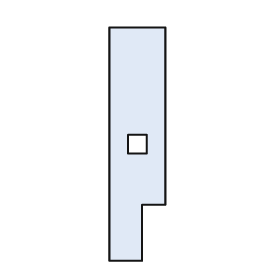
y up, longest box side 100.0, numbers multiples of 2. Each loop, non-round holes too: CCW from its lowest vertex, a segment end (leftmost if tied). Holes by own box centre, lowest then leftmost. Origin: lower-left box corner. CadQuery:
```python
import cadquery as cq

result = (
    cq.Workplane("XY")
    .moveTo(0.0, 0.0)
    .lineTo(14.0, 0.0)
    .lineTo(14.0, 24.0)
    .lineTo(24.0, 24.0)
    .lineTo(24.0, 100.0)
    .lineTo(0.0, 100.0)
    .close()
    .moveTo(8.0, 46.0)
    .lineTo(16.0, 46.0)
    .lineTo(16.0, 54.0)
    .lineTo(8.0, 54.0)
    .close()
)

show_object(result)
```